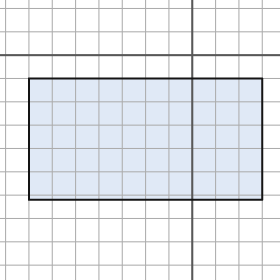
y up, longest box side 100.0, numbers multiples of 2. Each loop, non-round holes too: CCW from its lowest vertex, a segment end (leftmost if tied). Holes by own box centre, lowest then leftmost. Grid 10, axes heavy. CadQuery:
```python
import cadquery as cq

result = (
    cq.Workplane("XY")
    .moveTo(-70.0, -62.0)
    .lineTo(30.0, -62.0)
    .lineTo(30.0, -10.0)
    .lineTo(-70.0, -10.0)
    .close()
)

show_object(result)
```